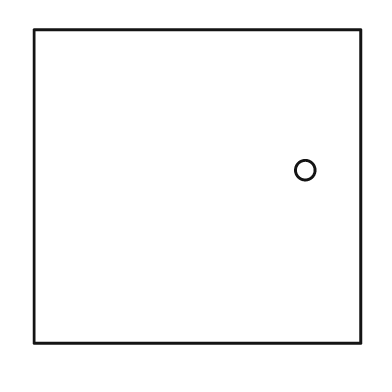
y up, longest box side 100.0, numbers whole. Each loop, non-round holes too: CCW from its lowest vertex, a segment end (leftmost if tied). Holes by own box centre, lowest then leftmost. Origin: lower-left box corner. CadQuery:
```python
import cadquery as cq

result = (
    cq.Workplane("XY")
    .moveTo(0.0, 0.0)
    .lineTo(100.0, 0.0)
    .lineTo(100.0, 96.0)
    .lineTo(0.0, 96.0)
    .close()
    .moveTo(83.0, 53.0)
    .circle(3.0)
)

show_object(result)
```